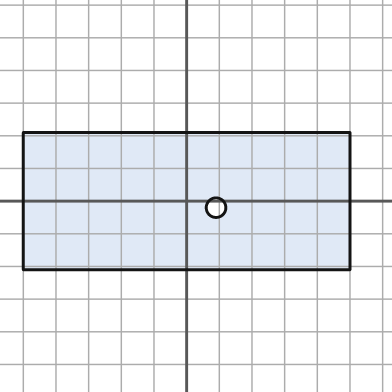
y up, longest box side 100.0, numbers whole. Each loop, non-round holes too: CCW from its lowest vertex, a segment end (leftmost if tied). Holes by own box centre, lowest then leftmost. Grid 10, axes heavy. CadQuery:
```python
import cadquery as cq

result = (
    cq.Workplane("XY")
    .moveTo(-50.0, -21.0)
    .lineTo(50.0, -21.0)
    .lineTo(50.0, 21.0)
    .lineTo(-50.0, 21.0)
    .close()
    .moveTo(9.0, -2.0)
    .circle(3.0)
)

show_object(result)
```